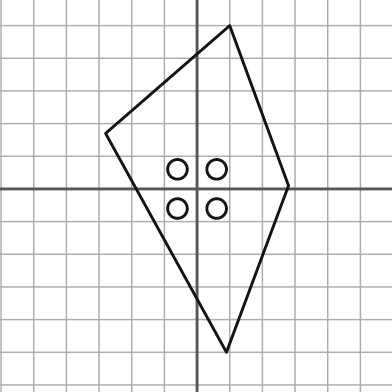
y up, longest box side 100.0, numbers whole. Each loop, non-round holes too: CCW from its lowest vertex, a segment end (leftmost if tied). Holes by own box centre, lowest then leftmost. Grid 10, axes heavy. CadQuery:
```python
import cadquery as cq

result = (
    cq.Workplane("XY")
    .moveTo(9.0, -50.0)
    .lineTo(28.0, 1.0)
    .lineTo(10.0, 50.0)
    .lineTo(-28.0, 17.0)
    .close()
    .moveTo(-6.0, -6.0)
    .circle(3.0)
    .moveTo(6.0, -6.0)
    .circle(3.0)
    .moveTo(-6.0, 6.0)
    .circle(3.0)
    .moveTo(6.0, 6.0)
    .circle(3.0)
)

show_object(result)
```